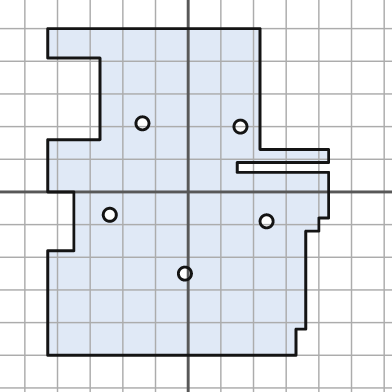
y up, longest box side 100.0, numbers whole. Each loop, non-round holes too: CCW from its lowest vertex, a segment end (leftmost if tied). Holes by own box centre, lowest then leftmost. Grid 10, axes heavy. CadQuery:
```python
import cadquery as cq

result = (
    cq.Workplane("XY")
    .moveTo(-43.0, -50.0)
    .lineTo(33.0, -50.0)
    .lineTo(33.0, -42.0)
    .lineTo(36.0, -42.0)
    .lineTo(36.0, -12.0)
    .lineTo(40.0, -12.0)
    .lineTo(40.0, -8.0)
    .lineTo(43.0, -8.0)
    .lineTo(43.0, 6.0)
    .lineTo(15.0, 6.0)
    .lineTo(15.0, 9.0)
    .lineTo(43.0, 9.0)
    .lineTo(43.0, 13.0)
    .lineTo(22.0, 13.0)
    .lineTo(22.0, 50.0)
    .lineTo(-43.0, 50.0)
    .lineTo(-43.0, 41.0)
    .lineTo(-27.0, 41.0)
    .lineTo(-27.0, 16.0)
    .lineTo(-43.0, 16.0)
    .lineTo(-43.0, 0.0)
    .lineTo(-35.0, 0.0)
    .lineTo(-35.0, -18.0)
    .lineTo(-43.0, -18.0)
    .close()
    .moveTo(-1.0, -25.0)
    .circle(2.0)
    .moveTo(24.0, -9.0)
    .circle(2.0)
    .moveTo(-24.0, -7.0)
    .circle(2.0)
    .moveTo(16.0, 20.0)
    .circle(2.0)
    .moveTo(-14.0, 21.0)
    .circle(2.0)
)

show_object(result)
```